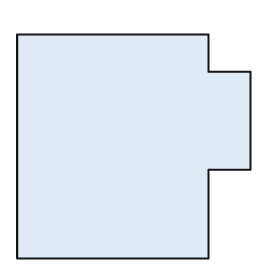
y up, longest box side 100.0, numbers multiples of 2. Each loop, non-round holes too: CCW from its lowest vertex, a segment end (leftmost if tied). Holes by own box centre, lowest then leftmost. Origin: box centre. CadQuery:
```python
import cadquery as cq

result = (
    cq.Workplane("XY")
    .moveTo(-50.0, -48.0)
    .lineTo(32.0, -48.0)
    .lineTo(32.0, -10.0)
    .lineTo(50.0, -10.0)
    .lineTo(50.0, 32.0)
    .lineTo(32.0, 32.0)
    .lineTo(32.0, 48.0)
    .lineTo(-50.0, 48.0)
    .close()
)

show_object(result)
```